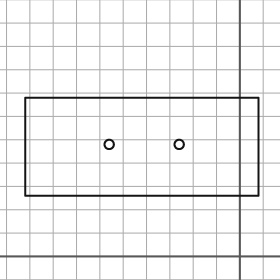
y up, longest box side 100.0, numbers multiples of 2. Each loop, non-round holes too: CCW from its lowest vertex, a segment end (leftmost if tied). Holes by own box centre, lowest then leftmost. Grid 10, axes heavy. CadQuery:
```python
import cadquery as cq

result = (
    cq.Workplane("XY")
    .moveTo(-92.0, 26.0)
    .lineTo(8.0, 26.0)
    .lineTo(8.0, 68.0)
    .lineTo(-92.0, 68.0)
    .close()
    .moveTo(-56.0, 48.0)
    .circle(2.0)
    .moveTo(-26.0, 48.0)
    .circle(2.0)
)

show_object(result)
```